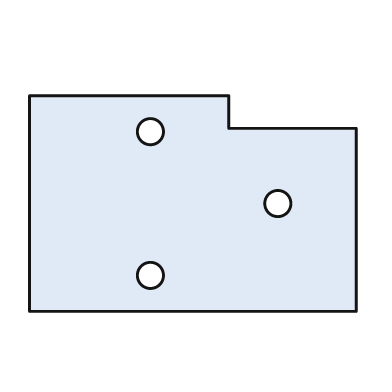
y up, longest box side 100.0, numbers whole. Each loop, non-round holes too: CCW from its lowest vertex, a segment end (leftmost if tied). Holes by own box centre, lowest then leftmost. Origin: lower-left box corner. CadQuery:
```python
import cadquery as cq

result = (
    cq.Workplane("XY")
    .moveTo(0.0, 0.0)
    .lineTo(100.0, 0.0)
    .lineTo(100.0, 56.0)
    .lineTo(61.0, 56.0)
    .lineTo(61.0, 66.0)
    .lineTo(0.0, 66.0)
    .close()
    .moveTo(37.0, 11.0)
    .circle(4.0)
    .moveTo(76.0, 33.0)
    .circle(4.0)
    .moveTo(37.0, 55.0)
    .circle(4.0)
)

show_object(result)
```